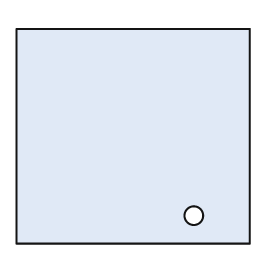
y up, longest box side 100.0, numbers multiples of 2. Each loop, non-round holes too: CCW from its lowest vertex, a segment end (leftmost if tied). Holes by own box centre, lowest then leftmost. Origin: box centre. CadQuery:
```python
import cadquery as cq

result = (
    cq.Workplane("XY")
    .moveTo(-50.0, -46.0)
    .lineTo(50.0, -46.0)
    .lineTo(50.0, 46.0)
    .lineTo(-50.0, 46.0)
    .close()
    .moveTo(26.0, -34.0)
    .circle(4.0)
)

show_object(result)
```